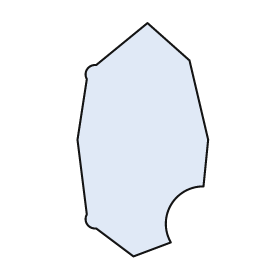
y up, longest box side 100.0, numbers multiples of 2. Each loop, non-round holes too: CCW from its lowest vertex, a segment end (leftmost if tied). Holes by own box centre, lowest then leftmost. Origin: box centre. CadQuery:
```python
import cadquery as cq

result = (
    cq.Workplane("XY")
    .moveTo(-4.0, -50.0)
    .lineTo(12.0, -44.0)
    .threePointArc((12.0, -28.0), (26.0, -20.0))
    .lineTo(28.0, 0.0)
    .lineTo(20.0, 34.0)
    .lineTo(2.0, 50.0)
    .lineTo(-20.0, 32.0)
    .threePointArc((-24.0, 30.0), (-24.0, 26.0))
    .lineTo(-28.0, 0.0)
    .lineTo(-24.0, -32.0)
    .threePointArc((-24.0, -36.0), (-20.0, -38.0))
    .close()
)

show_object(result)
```